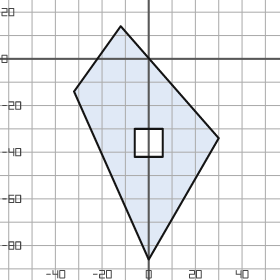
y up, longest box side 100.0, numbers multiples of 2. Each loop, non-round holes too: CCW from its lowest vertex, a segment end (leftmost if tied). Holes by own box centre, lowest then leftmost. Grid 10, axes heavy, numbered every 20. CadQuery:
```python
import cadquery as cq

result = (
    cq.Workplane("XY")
    .moveTo(0.0, -86.0)
    .lineTo(30.0, -34.0)
    .lineTo(-12.0, 14.0)
    .lineTo(-32.0, -14.0)
    .close()
    .moveTo(-6.0, -42.0)
    .lineTo(6.0, -42.0)
    .lineTo(6.0, -30.0)
    .lineTo(-6.0, -30.0)
    .close()
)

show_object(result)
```